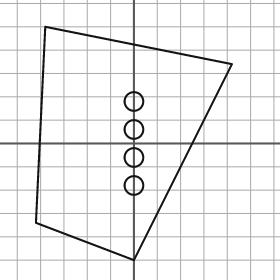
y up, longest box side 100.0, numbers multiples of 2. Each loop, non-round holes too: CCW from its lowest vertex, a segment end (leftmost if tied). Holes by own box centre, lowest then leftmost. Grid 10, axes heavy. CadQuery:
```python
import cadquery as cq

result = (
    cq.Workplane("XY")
    .moveTo(0.0, -50.0)
    .lineTo(42.0, 34.0)
    .lineTo(-38.0, 50.0)
    .lineTo(-42.0, -34.0)
    .close()
    .moveTo(0.0, -18.0)
    .circle(4.0)
    .moveTo(0.0, -6.0)
    .circle(4.0)
    .moveTo(0.0, 6.0)
    .circle(4.0)
    .moveTo(0.0, 18.0)
    .circle(4.0)
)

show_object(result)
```